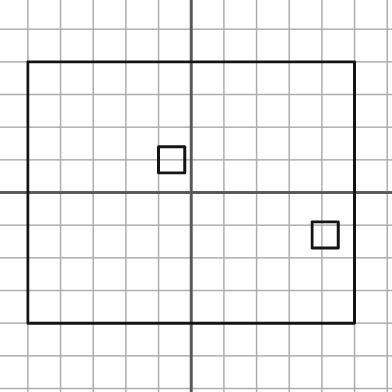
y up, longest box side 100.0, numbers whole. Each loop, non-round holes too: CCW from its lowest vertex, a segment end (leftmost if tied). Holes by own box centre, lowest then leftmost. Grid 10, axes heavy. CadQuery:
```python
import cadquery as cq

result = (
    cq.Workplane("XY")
    .moveTo(-50.0, -40.0)
    .lineTo(50.0, -40.0)
    .lineTo(50.0, 40.0)
    .lineTo(-50.0, 40.0)
    .close()
    .moveTo(37.0, -17.0)
    .lineTo(45.0, -17.0)
    .lineTo(45.0, -9.0)
    .lineTo(37.0, -9.0)
    .close()
    .moveTo(-10.0, 6.0)
    .lineTo(-2.0, 6.0)
    .lineTo(-2.0, 14.0)
    .lineTo(-10.0, 14.0)
    .close()
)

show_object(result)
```